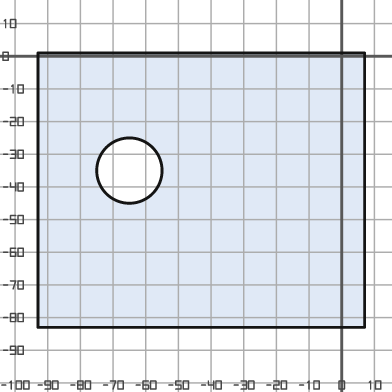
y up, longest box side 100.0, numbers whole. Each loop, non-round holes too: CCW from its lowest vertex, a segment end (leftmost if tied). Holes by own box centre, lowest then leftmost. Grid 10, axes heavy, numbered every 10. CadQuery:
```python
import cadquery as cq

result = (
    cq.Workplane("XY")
    .moveTo(-93.0, -83.0)
    .lineTo(7.0, -83.0)
    .lineTo(7.0, 1.0)
    .lineTo(-93.0, 1.0)
    .close()
    .moveTo(-65.0, -35.0)
    .circle(10.0)
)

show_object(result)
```